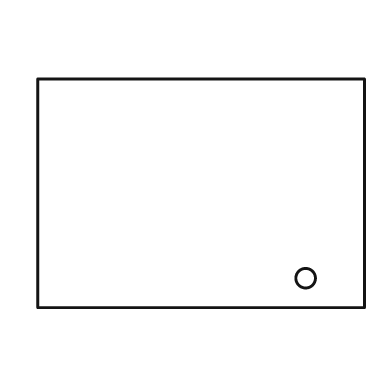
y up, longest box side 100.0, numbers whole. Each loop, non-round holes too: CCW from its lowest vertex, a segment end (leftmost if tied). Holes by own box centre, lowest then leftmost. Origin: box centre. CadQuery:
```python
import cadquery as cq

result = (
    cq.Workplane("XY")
    .moveTo(-50.0, -35.0)
    .lineTo(50.0, -35.0)
    .lineTo(50.0, 35.0)
    .lineTo(-50.0, 35.0)
    .close()
    .moveTo(32.0, -26.0)
    .circle(3.0)
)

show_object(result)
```